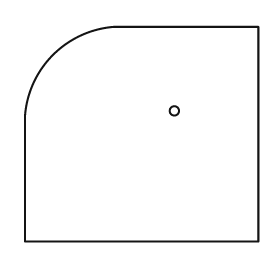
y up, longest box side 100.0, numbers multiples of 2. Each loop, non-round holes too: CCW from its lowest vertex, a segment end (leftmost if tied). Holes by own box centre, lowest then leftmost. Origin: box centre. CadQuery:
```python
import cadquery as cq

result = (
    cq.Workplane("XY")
    .moveTo(-50.0, -46.0)
    .lineTo(50.0, -46.0)
    .lineTo(50.0, 46.0)
    .lineTo(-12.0, 46.0)
    .threePointArc((-38.0, 34.0), (-50.0, 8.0))
    .close()
    .moveTo(14.0, 10.0)
    .circle(2.0)
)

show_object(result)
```